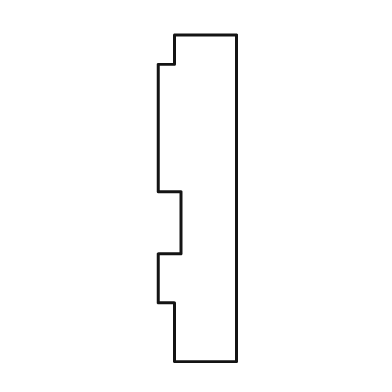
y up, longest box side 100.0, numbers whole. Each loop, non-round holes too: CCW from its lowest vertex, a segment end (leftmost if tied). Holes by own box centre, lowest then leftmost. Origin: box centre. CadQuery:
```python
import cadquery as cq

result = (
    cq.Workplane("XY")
    .moveTo(-7.0, -50.0)
    .lineTo(12.0, -50.0)
    .lineTo(12.0, 50.0)
    .lineTo(-7.0, 50.0)
    .lineTo(-7.0, 41.0)
    .lineTo(-12.0, 41.0)
    .lineTo(-12.0, 2.0)
    .lineTo(-5.0, 2.0)
    .lineTo(-5.0, -17.0)
    .lineTo(-12.0, -17.0)
    .lineTo(-12.0, -32.0)
    .lineTo(-7.0, -32.0)
    .close()
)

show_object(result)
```